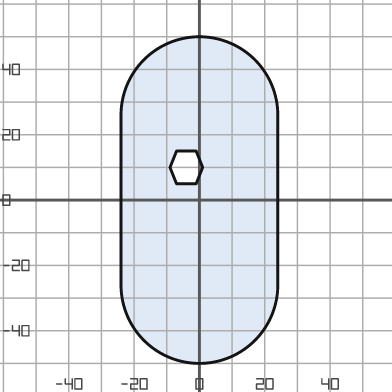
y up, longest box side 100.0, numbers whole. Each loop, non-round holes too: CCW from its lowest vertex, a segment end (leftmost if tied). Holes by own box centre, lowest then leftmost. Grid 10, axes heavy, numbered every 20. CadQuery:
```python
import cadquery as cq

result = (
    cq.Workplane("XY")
    .moveTo(-24.0, -26.0)
    .threePointArc((0.0, -50.0), (24.0, -26.0))
    .lineTo(24.0, 26.0)
    .threePointArc((0.0, 50.0), (-24.0, 26.0))
    .close()
    .moveTo(-7.0, 5.0)
    .lineTo(-1.0, 5.0)
    .lineTo(1.0, 10.0)
    .lineTo(-1.0, 15.0)
    .lineTo(-7.0, 15.0)
    .lineTo(-9.0, 10.0)
    .close()
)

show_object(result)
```